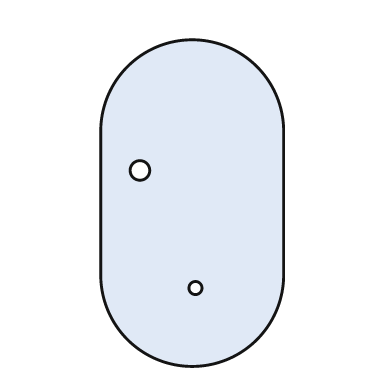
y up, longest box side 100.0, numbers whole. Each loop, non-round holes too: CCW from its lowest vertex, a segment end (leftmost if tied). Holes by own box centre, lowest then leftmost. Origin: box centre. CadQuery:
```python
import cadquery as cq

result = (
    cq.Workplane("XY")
    .moveTo(-28.0, -22.0)
    .threePointArc((0.0, -50.0), (28.0, -22.0))
    .lineTo(28.0, 22.0)
    .threePointArc((0.0, 50.0), (-28.0, 22.0))
    .close()
    .moveTo(1.0, -26.0)
    .circle(2.0)
    .moveTo(-16.0, 10.0)
    .circle(3.0)
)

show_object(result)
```